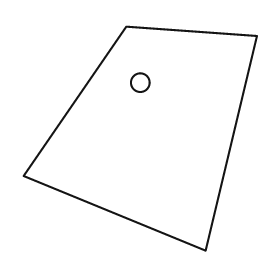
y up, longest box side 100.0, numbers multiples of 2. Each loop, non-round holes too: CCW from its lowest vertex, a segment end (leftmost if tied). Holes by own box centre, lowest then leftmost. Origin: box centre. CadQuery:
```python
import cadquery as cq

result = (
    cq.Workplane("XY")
    .moveTo(28.0, -48.0)
    .lineTo(50.0, 44.0)
    .lineTo(-6.0, 48.0)
    .lineTo(-50.0, -16.0)
    .close()
    .moveTo(0.0, 24.0)
    .circle(4.0)
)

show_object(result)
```